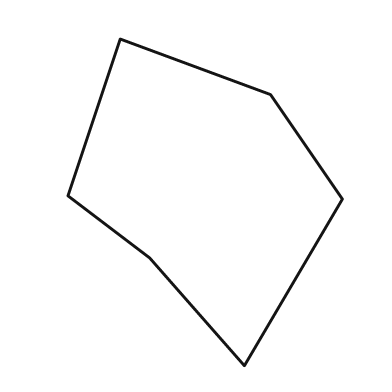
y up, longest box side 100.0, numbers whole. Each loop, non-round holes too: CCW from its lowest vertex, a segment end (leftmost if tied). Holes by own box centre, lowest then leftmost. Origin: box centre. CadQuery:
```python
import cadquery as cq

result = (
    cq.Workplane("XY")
    .moveTo(12.0, -50.0)
    .lineTo(42.0, 1.0)
    .lineTo(20.0, 33.0)
    .lineTo(-26.0, 50.0)
    .lineTo(-42.0, 2.0)
    .lineTo(-17.0, -17.0)
    .close()
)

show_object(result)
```